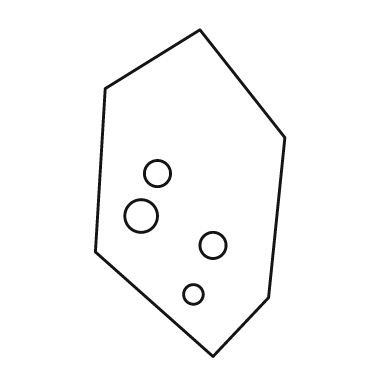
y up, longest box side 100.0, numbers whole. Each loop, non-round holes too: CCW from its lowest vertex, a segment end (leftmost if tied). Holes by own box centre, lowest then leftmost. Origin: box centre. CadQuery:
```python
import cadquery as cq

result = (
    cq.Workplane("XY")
    .moveTo(7.0, -50.0)
    .lineTo(24.0, -32.0)
    .lineTo(29.0, 17.0)
    .lineTo(3.0, 50.0)
    .lineTo(-26.0, 32.0)
    .lineTo(-29.0, -18.0)
    .close()
    .moveTo(1.0, -31.0)
    .circle(3.0)
    .moveTo(7.0, -16.0)
    .circle(4.0)
    .moveTo(-15.0, -7.0)
    .circle(5.0)
    .moveTo(-10.0, 6.0)
    .circle(4.0)
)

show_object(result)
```